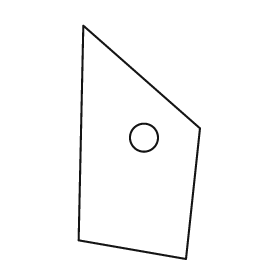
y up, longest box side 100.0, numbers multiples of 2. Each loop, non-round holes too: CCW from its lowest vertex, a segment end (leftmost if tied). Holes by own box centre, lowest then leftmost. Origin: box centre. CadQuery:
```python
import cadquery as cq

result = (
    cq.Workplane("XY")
    .moveTo(20.0, -50.0)
    .lineTo(26.0, 6.0)
    .lineTo(-24.0, 50.0)
    .lineTo(-26.0, -42.0)
    .close()
    .moveTo(2.0, 2.0)
    .circle(6.0)
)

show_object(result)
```